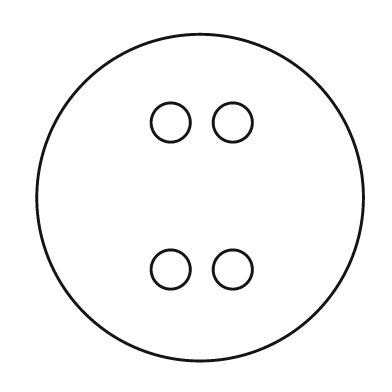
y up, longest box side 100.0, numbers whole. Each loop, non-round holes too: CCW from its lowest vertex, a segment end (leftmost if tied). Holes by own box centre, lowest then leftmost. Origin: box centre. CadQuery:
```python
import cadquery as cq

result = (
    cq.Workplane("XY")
    .moveTo(0.0, 0.0)
    .circle(50.0)
    .moveTo(-9.0, -22.0)
    .circle(6.0)
    .moveTo(10.0, -22.0)
    .circle(6.0)
    .moveTo(-9.0, 23.0)
    .circle(6.0)
    .moveTo(10.0, 23.0)
    .circle(6.0)
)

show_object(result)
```